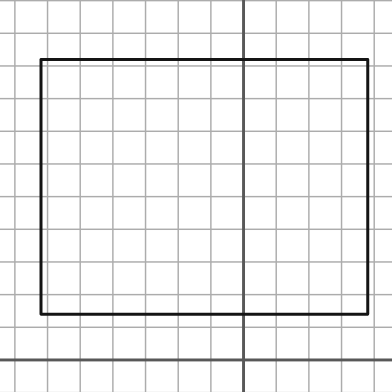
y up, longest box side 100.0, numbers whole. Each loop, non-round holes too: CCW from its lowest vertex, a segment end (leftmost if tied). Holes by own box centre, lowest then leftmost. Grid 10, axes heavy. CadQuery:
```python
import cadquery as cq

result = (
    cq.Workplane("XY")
    .moveTo(-62.0, 14.0)
    .lineTo(38.0, 14.0)
    .lineTo(38.0, 92.0)
    .lineTo(-62.0, 92.0)
    .close()
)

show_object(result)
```